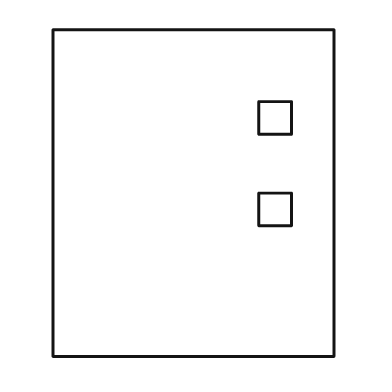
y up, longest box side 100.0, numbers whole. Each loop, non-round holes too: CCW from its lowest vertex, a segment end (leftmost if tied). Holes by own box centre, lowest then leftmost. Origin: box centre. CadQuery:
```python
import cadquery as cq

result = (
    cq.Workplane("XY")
    .moveTo(-43.0, -50.0)
    .lineTo(43.0, -50.0)
    .lineTo(43.0, 50.0)
    .lineTo(-43.0, 50.0)
    .close()
    .moveTo(20.0, -10.0)
    .lineTo(30.0, -10.0)
    .lineTo(30.0, 0.0)
    .lineTo(20.0, 0.0)
    .close()
    .moveTo(20.0, 18.0)
    .lineTo(30.0, 18.0)
    .lineTo(30.0, 28.0)
    .lineTo(20.0, 28.0)
    .close()
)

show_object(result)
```